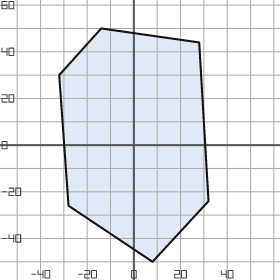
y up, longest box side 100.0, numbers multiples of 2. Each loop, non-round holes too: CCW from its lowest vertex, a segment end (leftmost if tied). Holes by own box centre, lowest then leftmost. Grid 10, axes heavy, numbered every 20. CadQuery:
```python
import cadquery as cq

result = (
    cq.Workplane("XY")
    .moveTo(8.0, -50.0)
    .lineTo(32.0, -24.0)
    .lineTo(28.0, 44.0)
    .lineTo(-14.0, 50.0)
    .lineTo(-32.0, 30.0)
    .lineTo(-28.0, -26.0)
    .close()
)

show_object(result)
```